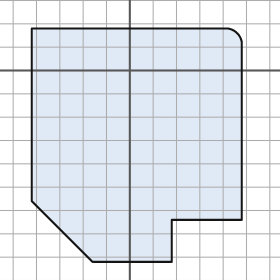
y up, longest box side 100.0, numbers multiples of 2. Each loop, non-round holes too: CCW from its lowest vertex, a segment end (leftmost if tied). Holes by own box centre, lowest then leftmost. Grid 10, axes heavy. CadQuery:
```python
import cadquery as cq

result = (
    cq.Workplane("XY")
    .moveTo(-16.0, -82.0)
    .lineTo(18.0, -82.0)
    .lineTo(18.0, -64.0)
    .lineTo(48.0, -64.0)
    .lineTo(48.0, 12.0)
    .threePointArc((46.0, 16.0), (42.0, 18.0))
    .lineTo(-42.0, 18.0)
    .lineTo(-42.0, -56.0)
    .close()
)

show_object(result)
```